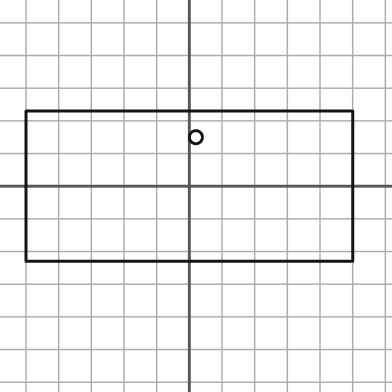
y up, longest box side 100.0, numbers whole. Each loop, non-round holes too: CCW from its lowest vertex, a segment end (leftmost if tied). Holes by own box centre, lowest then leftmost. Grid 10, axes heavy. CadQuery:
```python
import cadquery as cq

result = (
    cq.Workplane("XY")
    .moveTo(-50.0, -23.0)
    .lineTo(50.0, -23.0)
    .lineTo(50.0, 23.0)
    .lineTo(-50.0, 23.0)
    .close()
    .moveTo(2.0, 15.0)
    .circle(2.0)
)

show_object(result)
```